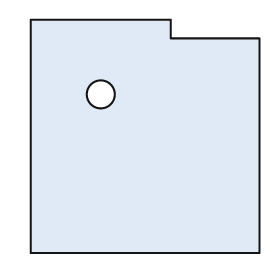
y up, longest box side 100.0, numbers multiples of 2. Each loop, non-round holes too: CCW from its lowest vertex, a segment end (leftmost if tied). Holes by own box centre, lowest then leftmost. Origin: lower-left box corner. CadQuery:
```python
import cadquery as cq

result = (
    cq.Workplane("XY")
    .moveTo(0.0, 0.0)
    .lineTo(98.0, 0.0)
    .lineTo(98.0, 92.0)
    .lineTo(60.0, 92.0)
    .lineTo(60.0, 100.0)
    .lineTo(0.0, 100.0)
    .close()
    .moveTo(30.0, 68.0)
    .circle(6.0)
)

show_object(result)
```